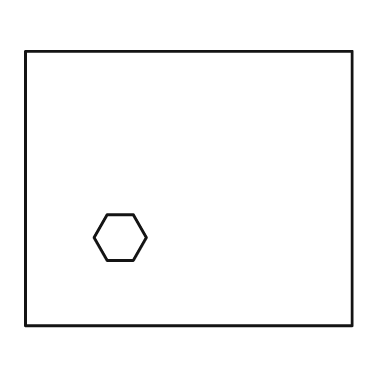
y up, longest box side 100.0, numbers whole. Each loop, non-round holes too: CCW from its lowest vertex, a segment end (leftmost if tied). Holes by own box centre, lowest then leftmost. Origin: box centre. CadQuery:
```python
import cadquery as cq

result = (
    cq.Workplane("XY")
    .moveTo(-50.0, -42.0)
    .lineTo(50.0, -42.0)
    .lineTo(50.0, 42.0)
    .lineTo(-50.0, 42.0)
    .close()
    .moveTo(-25.0, -22.0)
    .lineTo(-17.0, -22.0)
    .lineTo(-13.0, -15.0)
    .lineTo(-17.0, -8.0)
    .lineTo(-25.0, -8.0)
    .lineTo(-29.0, -15.0)
    .close()
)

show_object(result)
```